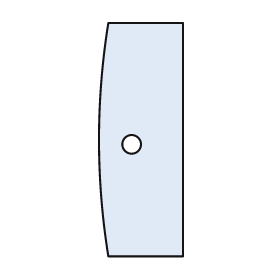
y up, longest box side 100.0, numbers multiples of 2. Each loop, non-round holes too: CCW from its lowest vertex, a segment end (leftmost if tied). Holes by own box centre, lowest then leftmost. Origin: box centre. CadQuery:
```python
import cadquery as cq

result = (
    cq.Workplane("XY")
    .moveTo(-14.0, -50.0)
    .lineTo(18.0, -50.0)
    .lineTo(18.0, 50.0)
    .lineTo(-14.0, 50.0)
    .threePointArc((-18.0, 0.0), (-14.0, -50.0))
    .close()
    .moveTo(-4.0, -2.0)
    .circle(4.0)
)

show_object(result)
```